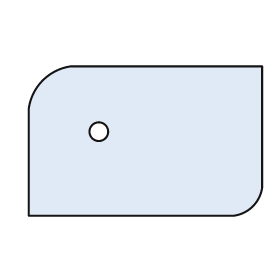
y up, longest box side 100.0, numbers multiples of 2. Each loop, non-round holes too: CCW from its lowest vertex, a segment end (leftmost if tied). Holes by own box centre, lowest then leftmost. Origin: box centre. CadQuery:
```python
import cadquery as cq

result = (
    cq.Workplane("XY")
    .moveTo(-50.0, -32.0)
    .lineTo(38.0, -32.0)
    .threePointArc((46.0, -28.0), (50.0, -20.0))
    .lineTo(50.0, 32.0)
    .lineTo(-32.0, 32.0)
    .threePointArc((-44.0, 26.0), (-50.0, 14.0))
    .close()
    .moveTo(-20.0, 4.0)
    .circle(4.0)
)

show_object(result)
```